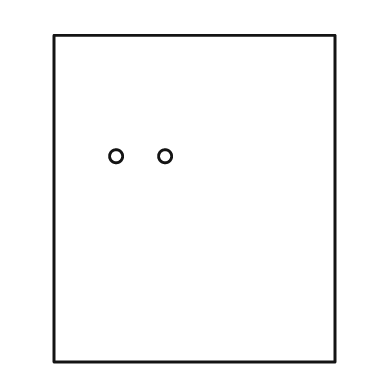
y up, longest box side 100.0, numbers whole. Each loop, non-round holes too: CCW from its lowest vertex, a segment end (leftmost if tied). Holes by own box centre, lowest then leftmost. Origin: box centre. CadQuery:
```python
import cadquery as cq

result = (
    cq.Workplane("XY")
    .moveTo(-43.0, -50.0)
    .lineTo(43.0, -50.0)
    .lineTo(43.0, 50.0)
    .lineTo(-43.0, 50.0)
    .close()
    .moveTo(-24.0, 13.0)
    .circle(2.0)
    .moveTo(-9.0, 13.0)
    .circle(2.0)
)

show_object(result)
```